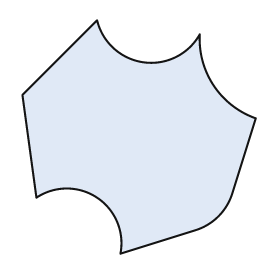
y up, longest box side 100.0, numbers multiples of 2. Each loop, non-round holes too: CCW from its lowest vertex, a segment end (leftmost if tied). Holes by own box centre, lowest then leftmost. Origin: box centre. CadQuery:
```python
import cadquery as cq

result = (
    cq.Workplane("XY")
    .moveTo(-8.0, -50.0)
    .lineTo(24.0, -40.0)
    .threePointArc((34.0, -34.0), (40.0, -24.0))
    .lineTo(50.0, 8.0)
    .threePointArc((32.0, 22.0), (26.0, 44.0))
    .threePointArc((2.0, 32.0), (-18.0, 50.0))
    .lineTo(-50.0, 18.0)
    .lineTo(-44.0, -26.0)
    .threePointArc((-18.0, -26.0), (-8.0, -50.0))
    .close()
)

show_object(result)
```